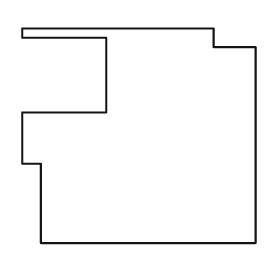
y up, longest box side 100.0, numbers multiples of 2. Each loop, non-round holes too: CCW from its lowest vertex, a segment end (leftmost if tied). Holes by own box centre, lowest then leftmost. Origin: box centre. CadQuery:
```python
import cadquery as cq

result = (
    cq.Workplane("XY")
    .moveTo(-42.0, -46.0)
    .lineTo(50.0, -46.0)
    .lineTo(50.0, 38.0)
    .lineTo(32.0, 38.0)
    .lineTo(32.0, 46.0)
    .lineTo(-50.0, 46.0)
    .lineTo(-50.0, 42.0)
    .lineTo(-14.0, 42.0)
    .lineTo(-14.0, 10.0)
    .lineTo(-50.0, 10.0)
    .lineTo(-50.0, -12.0)
    .lineTo(-42.0, -12.0)
    .close()
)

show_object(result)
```